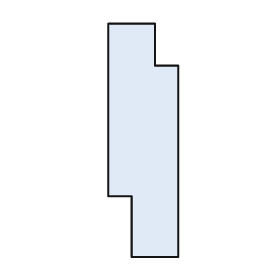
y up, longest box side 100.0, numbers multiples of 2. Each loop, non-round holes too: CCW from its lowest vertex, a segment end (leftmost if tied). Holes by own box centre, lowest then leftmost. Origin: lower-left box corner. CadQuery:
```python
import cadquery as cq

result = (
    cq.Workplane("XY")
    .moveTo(10.0, 0.0)
    .lineTo(30.0, 0.0)
    .lineTo(30.0, 82.0)
    .lineTo(20.0, 82.0)
    .lineTo(20.0, 100.0)
    .lineTo(0.0, 100.0)
    .lineTo(0.0, 26.0)
    .lineTo(10.0, 26.0)
    .close()
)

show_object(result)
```